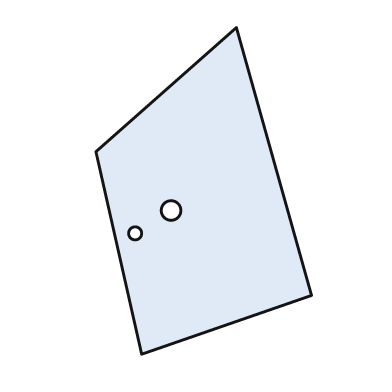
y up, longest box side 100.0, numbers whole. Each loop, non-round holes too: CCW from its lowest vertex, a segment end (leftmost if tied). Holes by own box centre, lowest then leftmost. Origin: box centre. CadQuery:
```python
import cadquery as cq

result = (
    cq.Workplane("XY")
    .moveTo(-19.0, -50.0)
    .lineTo(33.0, -32.0)
    .lineTo(10.0, 50.0)
    .lineTo(-33.0, 12.0)
    .close()
    .moveTo(-21.0, -13.0)
    .circle(2.0)
    .moveTo(-10.0, -6.0)
    .circle(3.0)
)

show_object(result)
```